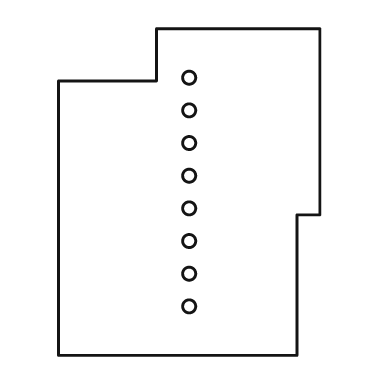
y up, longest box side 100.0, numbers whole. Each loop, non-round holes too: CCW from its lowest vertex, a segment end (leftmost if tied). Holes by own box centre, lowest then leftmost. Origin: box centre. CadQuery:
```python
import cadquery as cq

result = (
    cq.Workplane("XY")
    .moveTo(-40.0, -50.0)
    .lineTo(33.0, -50.0)
    .lineTo(33.0, -7.0)
    .lineTo(40.0, -7.0)
    .lineTo(40.0, 50.0)
    .lineTo(-10.0, 50.0)
    .lineTo(-10.0, 34.0)
    .lineTo(-40.0, 34.0)
    .close()
    .moveTo(0.0, -35.0)
    .circle(2.0)
    .moveTo(0.0, -25.0)
    .circle(2.0)
    .moveTo(0.0, -15.0)
    .circle(2.0)
    .moveTo(0.0, -5.0)
    .circle(2.0)
    .moveTo(0.0, 5.0)
    .circle(2.0)
    .moveTo(0.0, 15.0)
    .circle(2.0)
    .moveTo(0.0, 25.0)
    .circle(2.0)
    .moveTo(0.0, 35.0)
    .circle(2.0)
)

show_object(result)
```